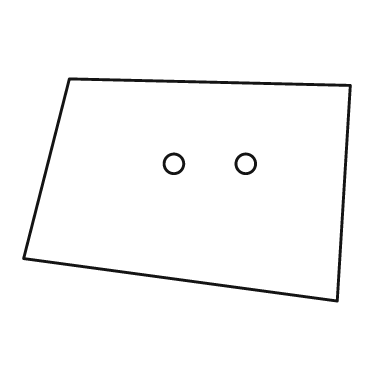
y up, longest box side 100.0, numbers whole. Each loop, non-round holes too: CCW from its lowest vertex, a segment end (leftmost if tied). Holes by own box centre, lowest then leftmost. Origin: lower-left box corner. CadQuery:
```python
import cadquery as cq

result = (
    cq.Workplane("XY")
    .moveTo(96.0, 0.0)
    .lineTo(100.0, 66.0)
    .lineTo(14.0, 68.0)
    .lineTo(0.0, 13.0)
    .close()
    .moveTo(46.0, 42.0)
    .circle(3.0)
    .moveTo(68.0, 42.0)
    .circle(3.0)
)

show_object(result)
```